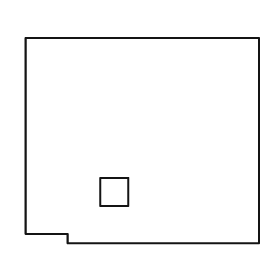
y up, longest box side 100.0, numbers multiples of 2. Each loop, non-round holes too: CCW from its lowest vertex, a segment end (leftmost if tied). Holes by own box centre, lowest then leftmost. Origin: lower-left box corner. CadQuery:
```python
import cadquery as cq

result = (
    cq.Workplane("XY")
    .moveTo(18.0, 0.0)
    .lineTo(100.0, 0.0)
    .lineTo(100.0, 88.0)
    .lineTo(0.0, 88.0)
    .lineTo(0.0, 4.0)
    .lineTo(18.0, 4.0)
    .close()
    .moveTo(32.0, 16.0)
    .lineTo(44.0, 16.0)
    .lineTo(44.0, 28.0)
    .lineTo(32.0, 28.0)
    .close()
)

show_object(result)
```